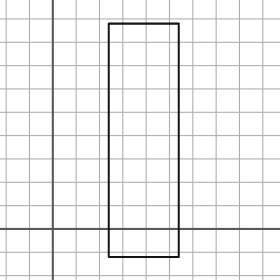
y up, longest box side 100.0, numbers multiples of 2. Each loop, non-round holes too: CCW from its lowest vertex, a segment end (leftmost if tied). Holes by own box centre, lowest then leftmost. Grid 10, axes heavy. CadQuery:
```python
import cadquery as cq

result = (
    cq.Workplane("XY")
    .moveTo(24.0, -12.0)
    .lineTo(54.0, -12.0)
    .lineTo(54.0, 88.0)
    .lineTo(24.0, 88.0)
    .close()
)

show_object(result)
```